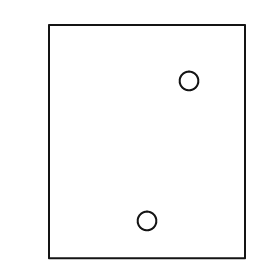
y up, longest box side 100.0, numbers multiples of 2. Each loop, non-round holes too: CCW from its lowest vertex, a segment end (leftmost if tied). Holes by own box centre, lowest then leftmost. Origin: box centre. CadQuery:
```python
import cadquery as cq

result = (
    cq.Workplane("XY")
    .moveTo(-42.0, -50.0)
    .lineTo(42.0, -50.0)
    .lineTo(42.0, 50.0)
    .lineTo(-42.0, 50.0)
    .close()
    .moveTo(0.0, -34.0)
    .circle(4.0)
    .moveTo(18.0, 26.0)
    .circle(4.0)
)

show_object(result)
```